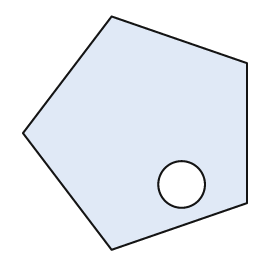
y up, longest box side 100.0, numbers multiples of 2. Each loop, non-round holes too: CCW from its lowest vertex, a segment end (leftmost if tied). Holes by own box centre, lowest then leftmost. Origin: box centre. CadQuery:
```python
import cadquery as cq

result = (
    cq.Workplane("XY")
    .moveTo(-10.0, -50.0)
    .lineTo(48.0, -30.0)
    .lineTo(48.0, 30.0)
    .lineTo(-10.0, 50.0)
    .lineTo(-48.0, 0.0)
    .close()
    .moveTo(20.0, -22.0)
    .circle(10.0)
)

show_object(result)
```